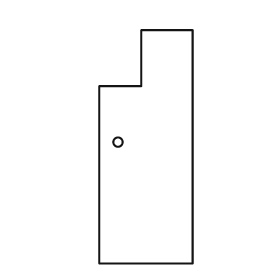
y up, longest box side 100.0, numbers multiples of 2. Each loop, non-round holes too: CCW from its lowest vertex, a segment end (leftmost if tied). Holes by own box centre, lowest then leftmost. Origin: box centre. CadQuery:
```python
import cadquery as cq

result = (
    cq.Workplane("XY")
    .moveTo(-20.0, -50.0)
    .lineTo(20.0, -50.0)
    .lineTo(20.0, 50.0)
    .lineTo(-2.0, 50.0)
    .lineTo(-2.0, 26.0)
    .lineTo(-20.0, 26.0)
    .close()
    .moveTo(-12.0, 2.0)
    .circle(2.0)
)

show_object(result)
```